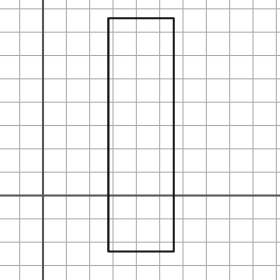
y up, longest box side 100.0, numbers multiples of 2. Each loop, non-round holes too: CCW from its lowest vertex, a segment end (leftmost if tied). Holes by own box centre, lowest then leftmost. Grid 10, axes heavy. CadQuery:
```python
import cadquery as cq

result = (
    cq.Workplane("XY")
    .moveTo(28.0, -24.0)
    .lineTo(56.0, -24.0)
    .lineTo(56.0, 76.0)
    .lineTo(28.0, 76.0)
    .close()
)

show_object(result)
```